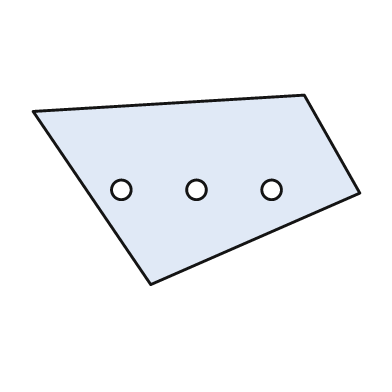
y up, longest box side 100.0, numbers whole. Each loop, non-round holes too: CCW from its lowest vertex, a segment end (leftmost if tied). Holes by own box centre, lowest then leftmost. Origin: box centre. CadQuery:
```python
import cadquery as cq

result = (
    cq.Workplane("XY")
    .moveTo(-14.0, -29.0)
    .lineTo(50.0, -1.0)
    .lineTo(33.0, 29.0)
    .lineTo(-50.0, 24.0)
    .close()
    .moveTo(-23.0, 0.0)
    .circle(3.0)
    .moveTo(0.0, 0.0)
    .circle(3.0)
    .moveTo(23.0, 0.0)
    .circle(3.0)
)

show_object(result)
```